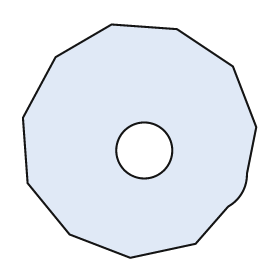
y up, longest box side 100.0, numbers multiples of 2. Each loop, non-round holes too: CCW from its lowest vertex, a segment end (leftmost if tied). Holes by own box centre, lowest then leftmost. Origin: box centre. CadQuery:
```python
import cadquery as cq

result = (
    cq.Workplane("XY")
    .moveTo(-4.0, -50.0)
    .lineTo(24.0, -44.0)
    .lineTo(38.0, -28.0)
    .threePointArc((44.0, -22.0), (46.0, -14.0))
    .lineTo(50.0, 6.0)
    .lineTo(40.0, 32.0)
    .lineTo(16.0, 48.0)
    .lineTo(-12.0, 50.0)
    .lineTo(-36.0, 36.0)
    .lineTo(-50.0, 10.0)
    .lineTo(-48.0, -18.0)
    .lineTo(-30.0, -40.0)
    .close()
    .moveTo(2.0, -4.0)
    .circle(12.0)
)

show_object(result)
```